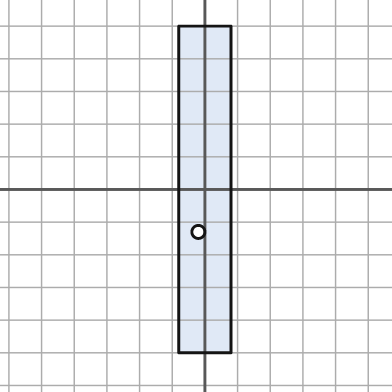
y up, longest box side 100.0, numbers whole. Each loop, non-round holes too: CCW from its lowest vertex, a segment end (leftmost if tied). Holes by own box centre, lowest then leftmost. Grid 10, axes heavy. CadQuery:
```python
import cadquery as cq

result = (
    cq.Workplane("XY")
    .moveTo(-8.0, -50.0)
    .lineTo(8.0, -50.0)
    .lineTo(8.0, 50.0)
    .lineTo(-8.0, 50.0)
    .close()
    .moveTo(-2.0, -13.0)
    .circle(2.0)
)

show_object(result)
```